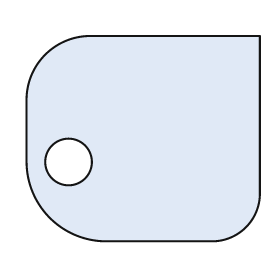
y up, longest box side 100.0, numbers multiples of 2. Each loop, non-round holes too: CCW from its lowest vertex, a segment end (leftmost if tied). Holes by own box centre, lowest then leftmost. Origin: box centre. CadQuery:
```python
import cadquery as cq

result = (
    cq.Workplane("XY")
    .moveTo(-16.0, -44.0)
    .lineTo(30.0, -44.0)
    .threePointArc((44.0, -38.0), (50.0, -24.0))
    .lineTo(50.0, 44.0)
    .lineTo(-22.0, 44.0)
    .threePointArc((-42.0, 36.0), (-50.0, 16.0))
    .lineTo(-50.0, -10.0)
    .threePointArc((-40.0, -34.0), (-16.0, -44.0))
    .close()
    .moveTo(-32.0, -10.0)
    .circle(10.0)
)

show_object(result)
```